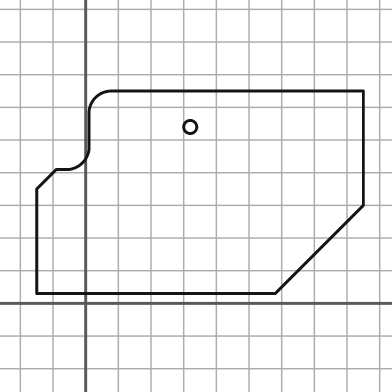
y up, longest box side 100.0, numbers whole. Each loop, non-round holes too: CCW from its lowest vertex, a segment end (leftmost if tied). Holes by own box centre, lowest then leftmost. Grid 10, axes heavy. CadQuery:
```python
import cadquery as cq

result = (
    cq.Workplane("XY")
    .moveTo(-15.0, 3.0)
    .lineTo(58.0, 3.0)
    .lineTo(85.0, 30.0)
    .lineTo(85.0, 65.0)
    .lineTo(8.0, 65.0)
    .threePointArc((3.0, 63.0), (1.0, 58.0))
    .lineTo(1.0, 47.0)
    .threePointArc((-1.0, 43.0), (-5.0, 41.0))
    .lineTo(-9.0, 41.0)
    .lineTo(-15.0, 35.0)
    .close()
    .moveTo(32.0, 54.0)
    .circle(2.0)
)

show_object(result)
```